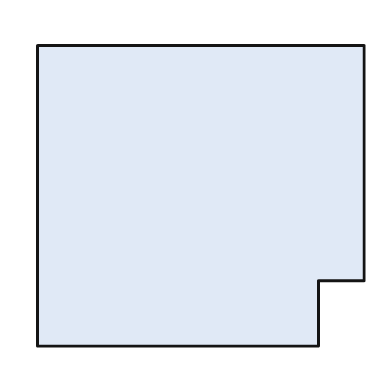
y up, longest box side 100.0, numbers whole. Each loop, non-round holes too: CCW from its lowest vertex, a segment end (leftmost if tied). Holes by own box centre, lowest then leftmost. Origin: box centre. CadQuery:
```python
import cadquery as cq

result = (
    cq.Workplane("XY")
    .moveTo(-50.0, -46.0)
    .lineTo(36.0, -46.0)
    .lineTo(36.0, -26.0)
    .lineTo(50.0, -26.0)
    .lineTo(50.0, 46.0)
    .lineTo(-50.0, 46.0)
    .close()
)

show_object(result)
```